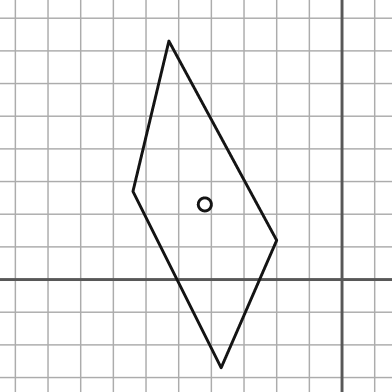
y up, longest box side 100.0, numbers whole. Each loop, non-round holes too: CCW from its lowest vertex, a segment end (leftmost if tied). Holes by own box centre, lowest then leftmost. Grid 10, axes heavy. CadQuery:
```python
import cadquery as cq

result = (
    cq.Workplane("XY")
    .moveTo(-37.0, -27.0)
    .lineTo(-20.0, 12.0)
    .lineTo(-53.0, 73.0)
    .lineTo(-64.0, 27.0)
    .close()
    .moveTo(-42.0, 23.0)
    .circle(2.0)
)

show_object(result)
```